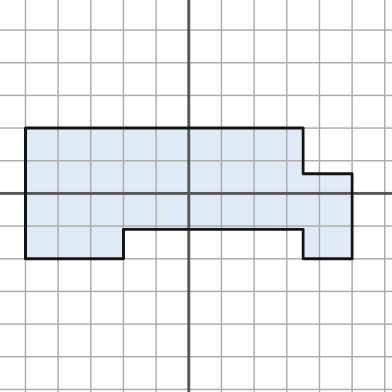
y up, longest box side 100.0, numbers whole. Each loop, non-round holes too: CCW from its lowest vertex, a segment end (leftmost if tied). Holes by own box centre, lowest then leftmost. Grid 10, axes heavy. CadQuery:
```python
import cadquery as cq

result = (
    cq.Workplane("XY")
    .moveTo(-50.0, -20.0)
    .lineTo(-20.0, -20.0)
    .lineTo(-20.0, -11.0)
    .lineTo(35.0, -11.0)
    .lineTo(35.0, -20.0)
    .lineTo(50.0, -20.0)
    .lineTo(50.0, 6.0)
    .lineTo(35.0, 6.0)
    .lineTo(35.0, 20.0)
    .lineTo(-50.0, 20.0)
    .close()
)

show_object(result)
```